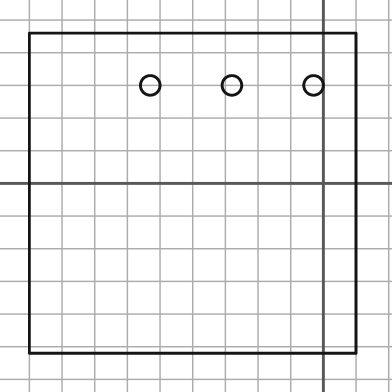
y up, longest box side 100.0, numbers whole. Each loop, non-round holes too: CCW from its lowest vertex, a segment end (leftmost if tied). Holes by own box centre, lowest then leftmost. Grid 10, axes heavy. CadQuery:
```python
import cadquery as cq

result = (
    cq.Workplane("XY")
    .moveTo(-90.0, -52.0)
    .lineTo(10.0, -52.0)
    .lineTo(10.0, 46.0)
    .lineTo(-90.0, 46.0)
    .close()
    .moveTo(-53.0, 30.0)
    .circle(3.0)
    .moveTo(-28.0, 30.0)
    .circle(3.0)
    .moveTo(-3.0, 30.0)
    .circle(3.0)
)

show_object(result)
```